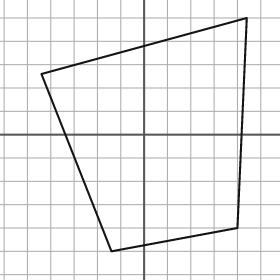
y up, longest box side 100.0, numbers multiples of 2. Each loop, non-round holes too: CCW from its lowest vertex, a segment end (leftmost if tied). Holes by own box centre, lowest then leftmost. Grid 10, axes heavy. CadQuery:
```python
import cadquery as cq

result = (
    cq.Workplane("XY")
    .moveTo(-14.0, -50.0)
    .lineTo(40.0, -40.0)
    .lineTo(44.0, 50.0)
    .lineTo(-44.0, 26.0)
    .close()
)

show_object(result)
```